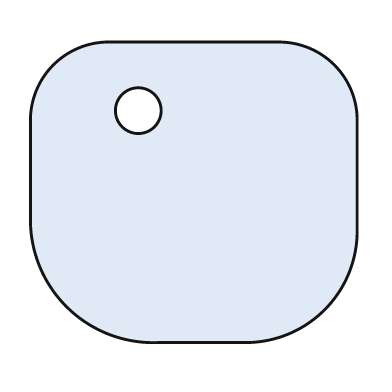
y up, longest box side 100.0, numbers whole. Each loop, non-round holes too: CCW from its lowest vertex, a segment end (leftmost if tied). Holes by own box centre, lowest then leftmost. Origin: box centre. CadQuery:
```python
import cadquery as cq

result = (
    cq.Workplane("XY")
    .moveTo(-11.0, -46.0)
    .lineTo(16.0, -46.0)
    .threePointArc((40.0, -36.0), (50.0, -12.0))
    .lineTo(50.0, 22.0)
    .threePointArc((43.0, 39.0), (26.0, 46.0))
    .lineTo(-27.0, 46.0)
    .threePointArc((-43.0, 39.0), (-50.0, 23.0))
    .lineTo(-50.0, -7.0)
    .threePointArc((-39.0, -35.0), (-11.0, -46.0))
    .close()
    .moveTo(-17.0, 25.0)
    .circle(7.0)
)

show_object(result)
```